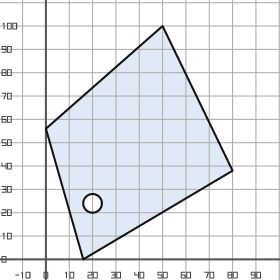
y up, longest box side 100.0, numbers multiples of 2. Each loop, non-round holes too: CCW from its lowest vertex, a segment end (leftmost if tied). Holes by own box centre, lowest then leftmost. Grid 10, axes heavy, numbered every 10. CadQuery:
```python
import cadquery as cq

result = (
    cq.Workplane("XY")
    .moveTo(16.0, 0.0)
    .lineTo(80.0, 38.0)
    .lineTo(50.0, 100.0)
    .lineTo(0.0, 56.0)
    .close()
    .moveTo(20.0, 24.0)
    .circle(4.0)
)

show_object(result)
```